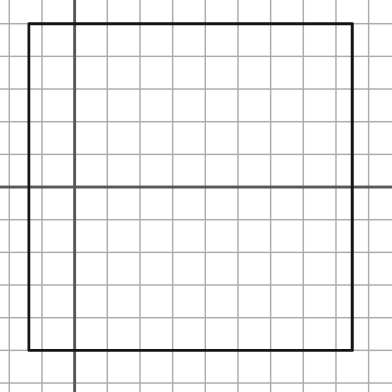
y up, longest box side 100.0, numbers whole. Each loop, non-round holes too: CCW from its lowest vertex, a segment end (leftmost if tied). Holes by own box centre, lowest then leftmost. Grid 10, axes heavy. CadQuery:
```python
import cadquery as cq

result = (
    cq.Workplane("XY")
    .moveTo(-14.0, -50.0)
    .lineTo(85.0, -50.0)
    .lineTo(85.0, 50.0)
    .lineTo(-14.0, 50.0)
    .close()
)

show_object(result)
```